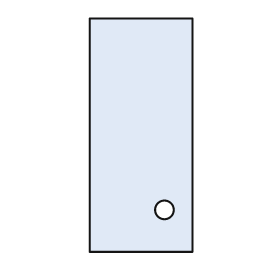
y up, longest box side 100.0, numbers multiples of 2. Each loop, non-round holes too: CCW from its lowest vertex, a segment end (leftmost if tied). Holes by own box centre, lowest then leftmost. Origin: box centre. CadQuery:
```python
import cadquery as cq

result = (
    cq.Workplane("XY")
    .moveTo(-22.0, -50.0)
    .lineTo(22.0, -50.0)
    .lineTo(22.0, 50.0)
    .lineTo(-22.0, 50.0)
    .close()
    .moveTo(10.0, -32.0)
    .circle(4.0)
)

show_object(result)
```